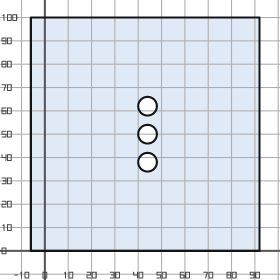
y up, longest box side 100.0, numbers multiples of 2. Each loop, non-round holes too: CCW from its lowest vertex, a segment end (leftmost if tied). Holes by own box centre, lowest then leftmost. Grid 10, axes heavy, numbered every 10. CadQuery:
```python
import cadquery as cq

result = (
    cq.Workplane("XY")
    .moveTo(-6.0, 0.0)
    .lineTo(92.0, 0.0)
    .lineTo(92.0, 100.0)
    .lineTo(-6.0, 100.0)
    .close()
    .moveTo(44.0, 38.0)
    .circle(4.0)
    .moveTo(44.0, 50.0)
    .circle(4.0)
    .moveTo(44.0, 62.0)
    .circle(4.0)
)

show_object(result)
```